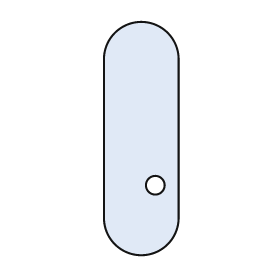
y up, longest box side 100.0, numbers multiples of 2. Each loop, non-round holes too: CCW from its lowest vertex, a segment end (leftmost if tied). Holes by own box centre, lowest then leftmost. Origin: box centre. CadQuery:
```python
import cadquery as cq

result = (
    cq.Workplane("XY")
    .moveTo(-16.0, -34.0)
    .threePointArc((0.0, -50.0), (16.0, -34.0))
    .lineTo(16.0, 34.0)
    .threePointArc((0.0, 50.0), (-16.0, 34.0))
    .close()
    .moveTo(6.0, -20.0)
    .circle(4.0)
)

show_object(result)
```